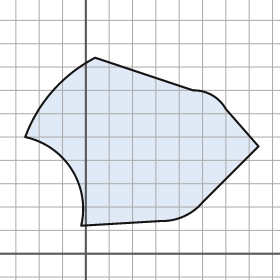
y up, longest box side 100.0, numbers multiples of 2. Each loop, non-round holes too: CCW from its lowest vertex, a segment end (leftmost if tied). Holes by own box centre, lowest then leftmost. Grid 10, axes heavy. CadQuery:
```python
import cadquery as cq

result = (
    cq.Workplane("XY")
    .moveTo(-2.0, 12.0)
    .lineTo(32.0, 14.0)
    .threePointArc((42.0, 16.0), (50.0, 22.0))
    .lineTo(74.0, 46.0)
    .lineTo(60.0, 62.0)
    .threePointArc((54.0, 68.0), (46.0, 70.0))
    .lineTo(4.0, 84.0)
    .threePointArc((-14.0, 70.0), (-26.0, 50.0))
    .threePointArc((-6.0, 36.0), (-2.0, 12.0))
    .close()
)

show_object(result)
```